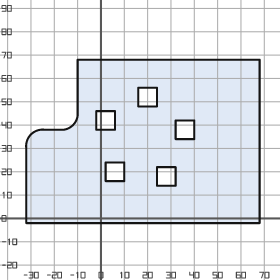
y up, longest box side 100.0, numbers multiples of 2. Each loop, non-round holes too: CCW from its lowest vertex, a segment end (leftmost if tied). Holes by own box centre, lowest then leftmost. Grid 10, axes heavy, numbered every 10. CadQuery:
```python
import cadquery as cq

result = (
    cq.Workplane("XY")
    .moveTo(-32.0, -2.0)
    .lineTo(68.0, -2.0)
    .lineTo(68.0, 68.0)
    .lineTo(-10.0, 68.0)
    .lineTo(-10.0, 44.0)
    .threePointArc((-12.0, 40.0), (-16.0, 38.0))
    .lineTo(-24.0, 38.0)
    .threePointArc((-30.0, 36.0), (-32.0, 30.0))
    .close()
    .moveTo(24.0, 14.0)
    .lineTo(32.0, 14.0)
    .lineTo(32.0, 22.0)
    .lineTo(24.0, 22.0)
    .close()
    .moveTo(2.0, 16.0)
    .lineTo(10.0, 16.0)
    .lineTo(10.0, 24.0)
    .lineTo(2.0, 24.0)
    .close()
    .moveTo(32.0, 34.0)
    .lineTo(40.0, 34.0)
    .lineTo(40.0, 42.0)
    .lineTo(32.0, 42.0)
    .close()
    .moveTo(-2.0, 38.0)
    .lineTo(6.0, 38.0)
    .lineTo(6.0, 46.0)
    .lineTo(-2.0, 46.0)
    .close()
    .moveTo(16.0, 48.0)
    .lineTo(24.0, 48.0)
    .lineTo(24.0, 56.0)
    .lineTo(16.0, 56.0)
    .close()
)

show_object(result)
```